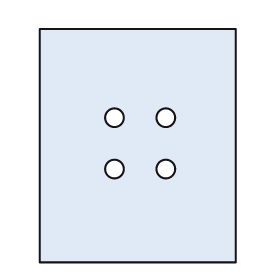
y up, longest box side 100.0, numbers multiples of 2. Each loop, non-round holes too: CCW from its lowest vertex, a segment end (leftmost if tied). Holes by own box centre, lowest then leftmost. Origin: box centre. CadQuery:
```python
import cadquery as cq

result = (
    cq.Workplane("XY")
    .moveTo(-42.0, -50.0)
    .lineTo(42.0, -50.0)
    .lineTo(42.0, 50.0)
    .lineTo(-42.0, 50.0)
    .close()
    .moveTo(-10.0, -10.0)
    .circle(4.0)
    .moveTo(12.0, -10.0)
    .circle(4.0)
    .moveTo(-10.0, 12.0)
    .circle(4.0)
    .moveTo(12.0, 12.0)
    .circle(4.0)
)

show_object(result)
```